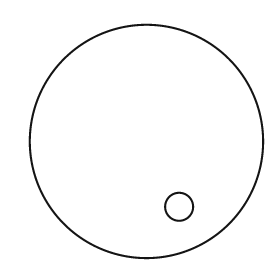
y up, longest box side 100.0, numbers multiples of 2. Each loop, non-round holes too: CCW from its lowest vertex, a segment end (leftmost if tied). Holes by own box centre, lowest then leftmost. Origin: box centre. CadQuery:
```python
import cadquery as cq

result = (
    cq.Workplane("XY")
    .moveTo(0.0, 0.0)
    .circle(50.0)
    .moveTo(14.0, -28.0)
    .circle(6.0)
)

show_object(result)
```